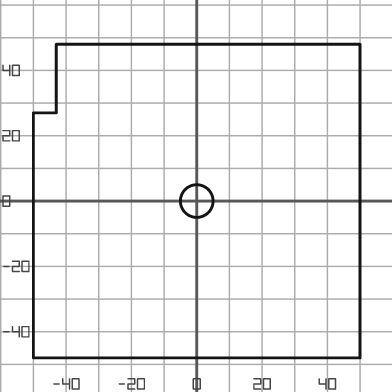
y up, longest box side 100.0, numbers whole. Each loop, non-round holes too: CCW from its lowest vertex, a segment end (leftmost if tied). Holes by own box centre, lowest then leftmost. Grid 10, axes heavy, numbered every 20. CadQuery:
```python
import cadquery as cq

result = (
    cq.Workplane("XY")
    .moveTo(-50.0, -48.0)
    .lineTo(50.0, -48.0)
    .lineTo(50.0, 48.0)
    .lineTo(-43.0, 48.0)
    .lineTo(-43.0, 27.0)
    .lineTo(-50.0, 27.0)
    .close()
    .moveTo(0.0, 0.0)
    .circle(5.0)
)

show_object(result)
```